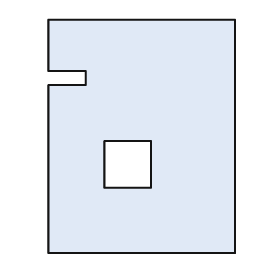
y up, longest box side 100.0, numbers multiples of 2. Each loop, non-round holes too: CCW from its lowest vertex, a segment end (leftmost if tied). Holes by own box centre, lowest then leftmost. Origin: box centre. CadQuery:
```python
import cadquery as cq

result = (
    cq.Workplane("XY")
    .moveTo(-40.0, -50.0)
    .lineTo(40.0, -50.0)
    .lineTo(40.0, 50.0)
    .lineTo(-40.0, 50.0)
    .lineTo(-40.0, 28.0)
    .lineTo(-24.0, 28.0)
    .lineTo(-24.0, 22.0)
    .lineTo(-40.0, 22.0)
    .close()
    .moveTo(-16.0, -22.0)
    .lineTo(4.0, -22.0)
    .lineTo(4.0, -2.0)
    .lineTo(-16.0, -2.0)
    .close()
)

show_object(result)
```